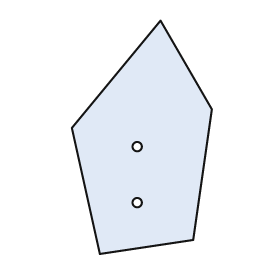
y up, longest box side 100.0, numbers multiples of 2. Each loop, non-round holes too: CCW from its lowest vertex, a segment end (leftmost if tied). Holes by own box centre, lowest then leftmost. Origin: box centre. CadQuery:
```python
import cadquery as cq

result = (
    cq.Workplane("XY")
    .moveTo(-18.0, -50.0)
    .lineTo(22.0, -44.0)
    .lineTo(30.0, 12.0)
    .lineTo(8.0, 50.0)
    .lineTo(-30.0, 4.0)
    .close()
    .moveTo(-2.0, -28.0)
    .circle(2.0)
    .moveTo(-2.0, -4.0)
    .circle(2.0)
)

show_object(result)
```